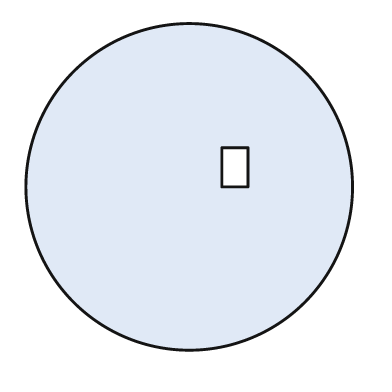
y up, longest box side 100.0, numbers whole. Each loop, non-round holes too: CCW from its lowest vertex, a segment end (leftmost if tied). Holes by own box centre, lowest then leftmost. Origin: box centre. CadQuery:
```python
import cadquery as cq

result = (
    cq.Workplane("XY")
    .moveTo(0.0, 0.0)
    .circle(50.0)
    .moveTo(10.0, 0.0)
    .lineTo(18.0, 0.0)
    .lineTo(18.0, 12.0)
    .lineTo(10.0, 12.0)
    .close()
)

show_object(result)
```